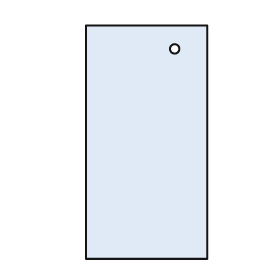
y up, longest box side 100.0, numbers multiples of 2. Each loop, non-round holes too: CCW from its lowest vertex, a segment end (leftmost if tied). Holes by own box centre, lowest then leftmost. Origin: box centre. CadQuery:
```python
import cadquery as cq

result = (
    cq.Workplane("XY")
    .moveTo(-26.0, -50.0)
    .lineTo(26.0, -50.0)
    .lineTo(26.0, 50.0)
    .lineTo(-26.0, 50.0)
    .close()
    .moveTo(12.0, 40.0)
    .circle(2.0)
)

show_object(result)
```